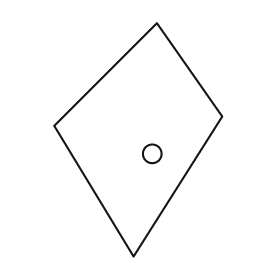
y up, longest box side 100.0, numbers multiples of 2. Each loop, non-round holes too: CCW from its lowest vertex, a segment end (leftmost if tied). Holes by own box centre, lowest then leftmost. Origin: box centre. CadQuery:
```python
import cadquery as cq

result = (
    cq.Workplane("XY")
    .moveTo(-2.0, -50.0)
    .lineTo(36.0, 10.0)
    .lineTo(8.0, 50.0)
    .lineTo(-36.0, 6.0)
    .close()
    .moveTo(6.0, -6.0)
    .circle(4.0)
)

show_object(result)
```